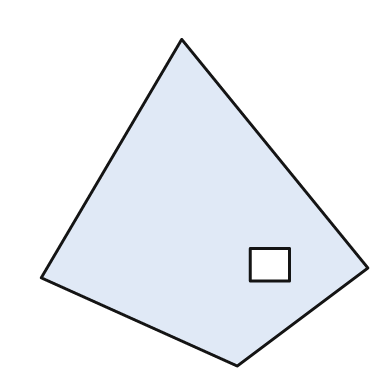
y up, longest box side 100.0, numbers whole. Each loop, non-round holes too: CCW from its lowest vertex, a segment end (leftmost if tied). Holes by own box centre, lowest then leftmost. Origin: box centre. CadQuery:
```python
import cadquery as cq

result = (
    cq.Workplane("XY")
    .moveTo(10.0, -50.0)
    .lineTo(50.0, -20.0)
    .lineTo(-7.0, 50.0)
    .lineTo(-50.0, -23.0)
    .close()
    .moveTo(14.0, -24.0)
    .lineTo(26.0, -24.0)
    .lineTo(26.0, -14.0)
    .lineTo(14.0, -14.0)
    .close()
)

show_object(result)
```